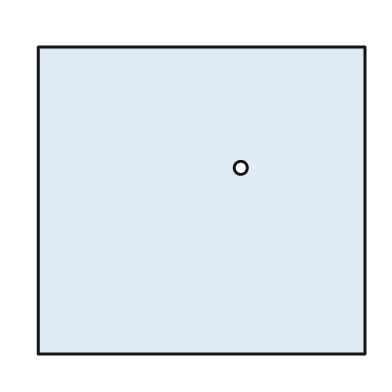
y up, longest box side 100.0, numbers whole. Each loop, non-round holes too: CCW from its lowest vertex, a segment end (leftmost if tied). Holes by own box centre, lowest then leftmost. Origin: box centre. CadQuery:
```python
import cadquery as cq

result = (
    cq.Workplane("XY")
    .moveTo(-50.0, -47.0)
    .lineTo(50.0, -47.0)
    .lineTo(50.0, 47.0)
    .lineTo(-50.0, 47.0)
    .close()
    .moveTo(12.0, 10.0)
    .circle(2.0)
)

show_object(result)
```